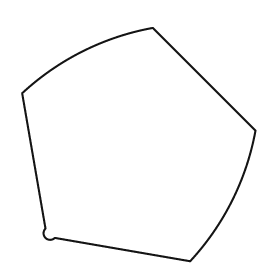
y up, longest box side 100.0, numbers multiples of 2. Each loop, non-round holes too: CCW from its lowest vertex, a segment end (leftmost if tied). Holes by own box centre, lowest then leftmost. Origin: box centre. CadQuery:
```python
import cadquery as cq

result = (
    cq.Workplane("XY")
    .moveTo(22.0, -50.0)
    .threePointArc((40.0, -24.0), (50.0, 6.0))
    .lineTo(6.0, 50.0)
    .threePointArc((-24.0, 40.0), (-50.0, 22.0))
    .lineTo(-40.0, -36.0)
    .threePointArc((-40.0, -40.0), (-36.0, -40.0))
    .close()
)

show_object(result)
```